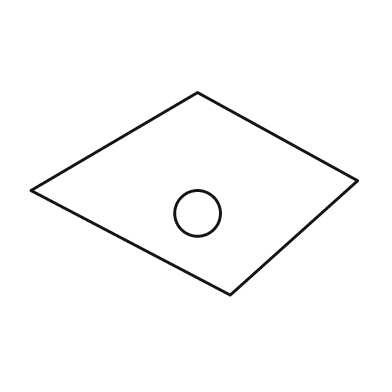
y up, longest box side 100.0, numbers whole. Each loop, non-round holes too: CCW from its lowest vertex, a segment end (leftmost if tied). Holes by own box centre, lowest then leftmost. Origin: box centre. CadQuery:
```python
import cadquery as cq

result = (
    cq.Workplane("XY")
    .moveTo(11.0, -31.0)
    .lineTo(50.0, 4.0)
    .lineTo(1.0, 31.0)
    .lineTo(-50.0, 1.0)
    .close()
    .moveTo(1.0, -6.0)
    .circle(7.0)
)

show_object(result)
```